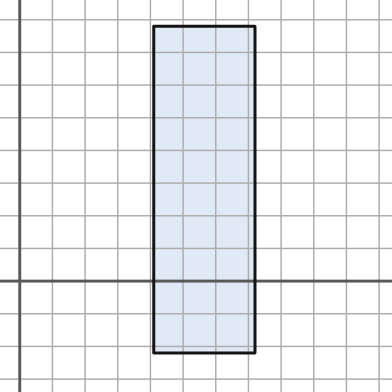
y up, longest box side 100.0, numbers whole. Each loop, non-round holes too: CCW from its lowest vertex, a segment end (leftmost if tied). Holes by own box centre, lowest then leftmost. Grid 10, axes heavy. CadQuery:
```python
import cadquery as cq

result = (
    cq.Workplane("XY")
    .moveTo(41.0, -22.0)
    .lineTo(72.0, -22.0)
    .lineTo(72.0, 78.0)
    .lineTo(41.0, 78.0)
    .close()
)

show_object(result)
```